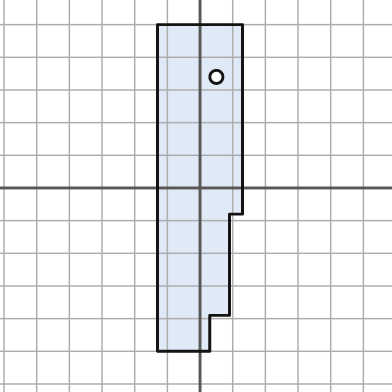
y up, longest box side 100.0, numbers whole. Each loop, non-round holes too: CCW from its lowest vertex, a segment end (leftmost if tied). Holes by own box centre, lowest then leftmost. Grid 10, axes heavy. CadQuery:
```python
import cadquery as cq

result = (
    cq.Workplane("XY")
    .moveTo(-13.0, -50.0)
    .lineTo(3.0, -50.0)
    .lineTo(3.0, -39.0)
    .lineTo(9.0, -39.0)
    .lineTo(9.0, -8.0)
    .lineTo(13.0, -8.0)
    .lineTo(13.0, 50.0)
    .lineTo(-13.0, 50.0)
    .close()
    .moveTo(5.0, 34.0)
    .circle(2.0)
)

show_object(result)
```